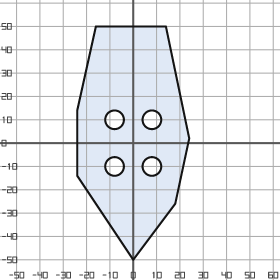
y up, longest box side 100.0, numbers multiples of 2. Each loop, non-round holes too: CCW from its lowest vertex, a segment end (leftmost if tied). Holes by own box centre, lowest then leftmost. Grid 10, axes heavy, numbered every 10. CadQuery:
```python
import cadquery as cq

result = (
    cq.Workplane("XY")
    .moveTo(0.0, -50.0)
    .lineTo(18.0, -26.0)
    .lineTo(24.0, 2.0)
    .lineTo(14.0, 50.0)
    .lineTo(-16.0, 50.0)
    .lineTo(-24.0, 14.0)
    .lineTo(-24.0, -14.0)
    .close()
    .moveTo(-8.0, -10.0)
    .circle(4.0)
    .moveTo(8.0, -10.0)
    .circle(4.0)
    .moveTo(-8.0, 10.0)
    .circle(4.0)
    .moveTo(8.0, 10.0)
    .circle(4.0)
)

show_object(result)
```